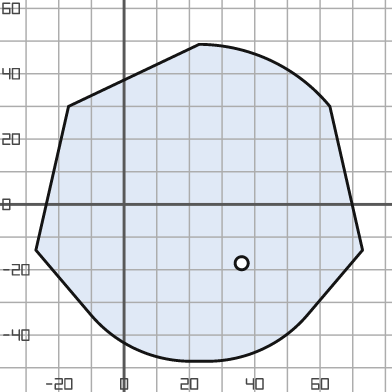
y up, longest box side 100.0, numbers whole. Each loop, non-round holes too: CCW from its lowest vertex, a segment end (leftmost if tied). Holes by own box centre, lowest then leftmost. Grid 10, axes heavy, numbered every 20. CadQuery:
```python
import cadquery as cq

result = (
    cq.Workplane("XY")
    .moveTo(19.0, -48.0)
    .lineTo(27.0, -48.0)
    .threePointArc((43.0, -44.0), (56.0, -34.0))
    .lineTo(73.0, -14.0)
    .lineTo(63.0, 30.0)
    .threePointArc((45.0, 44.0), (23.0, 49.0))
    .lineTo(-17.0, 30.0)
    .lineTo(-27.0, -14.0)
    .lineTo(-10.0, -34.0)
    .threePointArc((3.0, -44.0), (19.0, -48.0))
    .close()
    .moveTo(36.0, -18.0)
    .circle(2.0)
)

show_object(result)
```